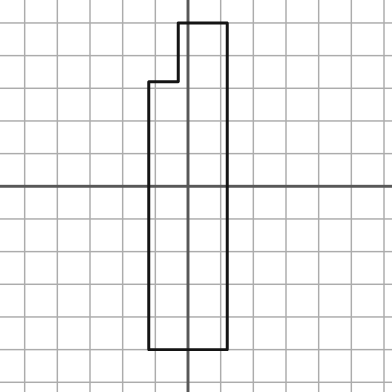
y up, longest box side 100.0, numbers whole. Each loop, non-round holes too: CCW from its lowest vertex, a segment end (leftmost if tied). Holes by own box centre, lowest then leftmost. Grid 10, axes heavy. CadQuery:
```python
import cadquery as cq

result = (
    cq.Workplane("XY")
    .moveTo(-12.0, -50.0)
    .lineTo(12.0, -50.0)
    .lineTo(12.0, 50.0)
    .lineTo(-3.0, 50.0)
    .lineTo(-3.0, 32.0)
    .lineTo(-12.0, 32.0)
    .close()
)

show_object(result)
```